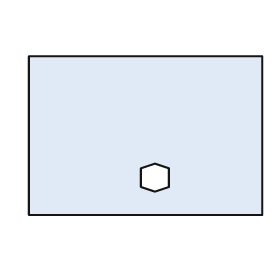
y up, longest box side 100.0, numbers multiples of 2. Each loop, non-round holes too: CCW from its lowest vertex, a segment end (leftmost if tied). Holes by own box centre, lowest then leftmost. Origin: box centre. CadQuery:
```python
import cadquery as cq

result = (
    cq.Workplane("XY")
    .moveTo(-50.0, -34.0)
    .lineTo(50.0, -34.0)
    .lineTo(50.0, 34.0)
    .lineTo(-50.0, 34.0)
    .close()
    .moveTo(4.0, -24.0)
    .lineTo(10.0, -22.0)
    .lineTo(10.0, -14.0)
    .lineTo(4.0, -12.0)
    .lineTo(-2.0, -14.0)
    .lineTo(-2.0, -22.0)
    .close()
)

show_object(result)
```